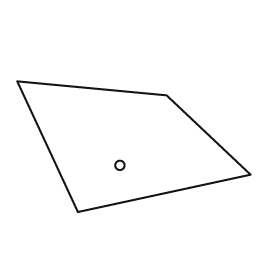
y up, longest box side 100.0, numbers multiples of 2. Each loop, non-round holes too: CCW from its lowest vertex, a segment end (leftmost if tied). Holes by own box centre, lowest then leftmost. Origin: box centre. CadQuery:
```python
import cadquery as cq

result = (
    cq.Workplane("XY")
    .moveTo(-24.0, -28.0)
    .lineTo(50.0, -12.0)
    .lineTo(14.0, 22.0)
    .lineTo(-50.0, 28.0)
    .close()
    .moveTo(-6.0, -8.0)
    .circle(2.0)
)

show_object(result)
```